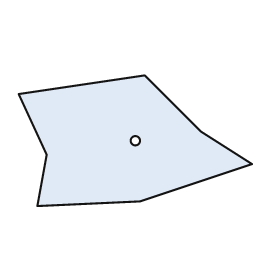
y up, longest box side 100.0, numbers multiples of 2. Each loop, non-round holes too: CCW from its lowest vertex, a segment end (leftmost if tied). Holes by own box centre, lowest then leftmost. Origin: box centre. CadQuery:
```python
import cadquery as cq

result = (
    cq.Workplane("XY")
    .moveTo(-42.0, -28.0)
    .lineTo(2.0, -26.0)
    .lineTo(50.0, -10.0)
    .lineTo(28.0, 4.0)
    .lineTo(4.0, 28.0)
    .lineTo(-50.0, 20.0)
    .lineTo(-38.0, -6.0)
    .close()
    .moveTo(0.0, 0.0)
    .circle(2.0)
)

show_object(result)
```